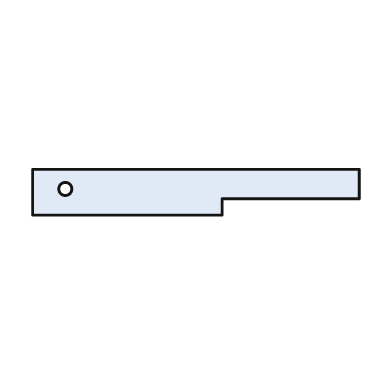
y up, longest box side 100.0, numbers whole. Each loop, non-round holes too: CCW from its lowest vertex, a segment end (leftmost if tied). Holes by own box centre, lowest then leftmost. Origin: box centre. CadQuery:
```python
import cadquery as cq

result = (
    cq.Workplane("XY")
    .moveTo(-50.0, -7.0)
    .lineTo(8.0, -7.0)
    .lineTo(8.0, -2.0)
    .lineTo(50.0, -2.0)
    .lineTo(50.0, 7.0)
    .lineTo(-50.0, 7.0)
    .close()
    .moveTo(-40.0, 1.0)
    .circle(2.0)
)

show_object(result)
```